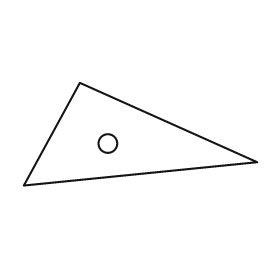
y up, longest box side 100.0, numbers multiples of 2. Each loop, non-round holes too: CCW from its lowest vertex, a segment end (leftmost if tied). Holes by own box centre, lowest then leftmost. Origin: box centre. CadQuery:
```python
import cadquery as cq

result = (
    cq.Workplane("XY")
    .moveTo(-50.0, -22.0)
    .lineTo(50.0, -12.0)
    .lineTo(-26.0, 22.0)
    .close()
    .moveTo(-14.0, -4.0)
    .circle(4.0)
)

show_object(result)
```